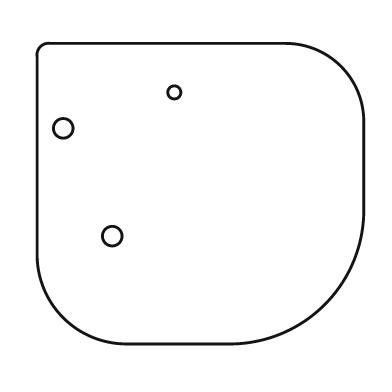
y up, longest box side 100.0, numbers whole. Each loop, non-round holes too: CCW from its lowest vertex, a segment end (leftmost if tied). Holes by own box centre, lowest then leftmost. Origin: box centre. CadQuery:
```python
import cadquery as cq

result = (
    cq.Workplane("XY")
    .moveTo(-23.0, -46.0)
    .lineTo(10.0, -46.0)
    .threePointArc((38.0, -34.0), (50.0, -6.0))
    .lineTo(50.0, 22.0)
    .threePointArc((43.0, 39.0), (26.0, 46.0))
    .lineTo(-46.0, 46.0)
    .threePointArc((-49.0, 45.0), (-50.0, 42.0))
    .lineTo(-50.0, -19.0)
    .threePointArc((-42.0, -38.0), (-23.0, -46.0))
    .close()
    .moveTo(-27.0, -13.0)
    .circle(3.0)
    .moveTo(-42.0, 20.0)
    .circle(3.0)
    .moveTo(-8.0, 31.0)
    .circle(2.0)
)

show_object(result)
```